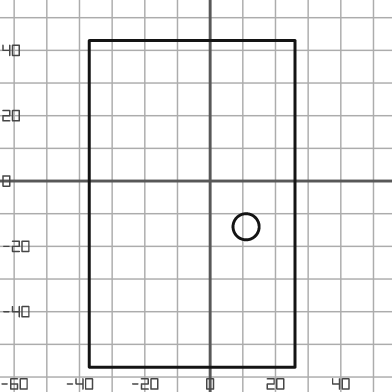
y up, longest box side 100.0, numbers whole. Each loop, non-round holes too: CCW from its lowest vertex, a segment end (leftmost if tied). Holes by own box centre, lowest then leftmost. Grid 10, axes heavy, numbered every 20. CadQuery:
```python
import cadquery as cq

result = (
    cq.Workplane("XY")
    .moveTo(-37.0, -57.0)
    .lineTo(26.0, -57.0)
    .lineTo(26.0, 43.0)
    .lineTo(-37.0, 43.0)
    .close()
    .moveTo(11.0, -14.0)
    .circle(4.0)
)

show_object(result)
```